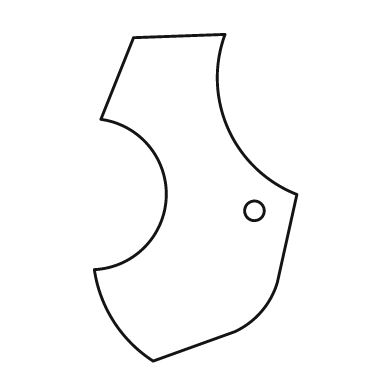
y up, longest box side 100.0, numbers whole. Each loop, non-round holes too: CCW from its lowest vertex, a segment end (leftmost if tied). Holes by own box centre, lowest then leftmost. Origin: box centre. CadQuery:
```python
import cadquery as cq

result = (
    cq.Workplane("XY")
    .moveTo(-13.0, -50.0)
    .lineTo(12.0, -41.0)
    .threePointArc((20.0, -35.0), (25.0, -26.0))
    .lineTo(31.0, 1.0)
    .threePointArc((10.0, 21.0), (9.0, 50.0))
    .lineTo(-19.0, 49.0)
    .lineTo(-29.0, 24.0)
    .threePointArc((-9.0, 0.0), (-31.0, -22.0))
    .threePointArc((-25.0, -38.0), (-13.0, -50.0))
    .close()
    .moveTo(18.0, -4.0)
    .circle(3.0)
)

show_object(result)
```